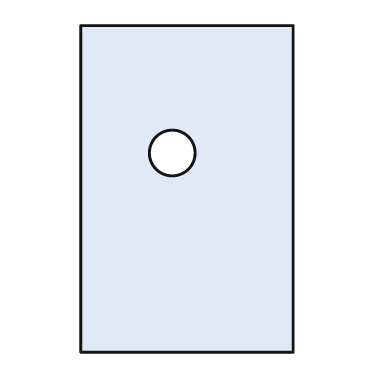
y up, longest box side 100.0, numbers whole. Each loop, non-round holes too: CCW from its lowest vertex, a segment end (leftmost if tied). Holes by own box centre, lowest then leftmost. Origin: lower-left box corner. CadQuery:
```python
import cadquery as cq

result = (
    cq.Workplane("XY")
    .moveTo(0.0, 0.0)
    .lineTo(65.0, 0.0)
    .lineTo(65.0, 100.0)
    .lineTo(0.0, 100.0)
    .close()
    .moveTo(28.0, 61.0)
    .circle(7.0)
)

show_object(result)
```